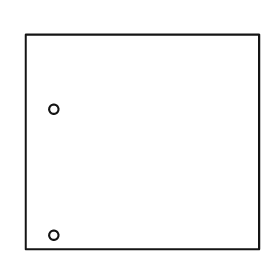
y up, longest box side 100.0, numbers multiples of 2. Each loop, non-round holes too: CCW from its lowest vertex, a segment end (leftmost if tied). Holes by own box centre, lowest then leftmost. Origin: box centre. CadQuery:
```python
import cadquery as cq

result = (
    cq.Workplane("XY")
    .moveTo(-50.0, -46.0)
    .lineTo(50.0, -46.0)
    .lineTo(50.0, 46.0)
    .lineTo(-50.0, 46.0)
    .close()
    .moveTo(-38.0, -40.0)
    .circle(2.0)
    .moveTo(-38.0, 14.0)
    .circle(2.0)
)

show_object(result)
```